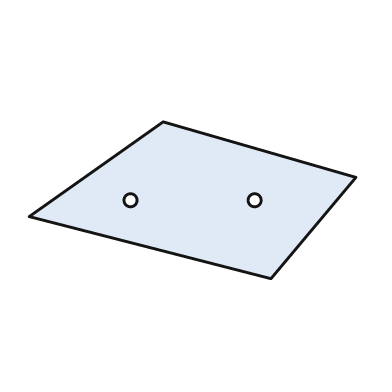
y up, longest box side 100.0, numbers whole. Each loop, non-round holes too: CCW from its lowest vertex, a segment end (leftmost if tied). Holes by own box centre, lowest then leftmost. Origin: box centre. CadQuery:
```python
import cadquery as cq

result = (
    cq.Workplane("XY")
    .moveTo(24.0, -24.0)
    .lineTo(50.0, 7.0)
    .lineTo(-9.0, 24.0)
    .lineTo(-50.0, -5.0)
    .close()
    .moveTo(-19.0, 0.0)
    .circle(2.0)
    .moveTo(19.0, 0.0)
    .circle(2.0)
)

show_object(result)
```